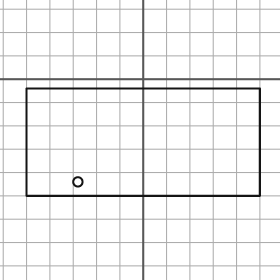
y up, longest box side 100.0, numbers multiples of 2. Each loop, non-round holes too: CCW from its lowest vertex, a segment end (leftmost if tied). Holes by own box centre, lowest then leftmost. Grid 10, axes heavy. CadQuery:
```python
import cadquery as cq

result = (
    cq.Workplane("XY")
    .moveTo(-50.0, -50.0)
    .lineTo(50.0, -50.0)
    .lineTo(50.0, -4.0)
    .lineTo(-50.0, -4.0)
    .close()
    .moveTo(-28.0, -44.0)
    .circle(2.0)
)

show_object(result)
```